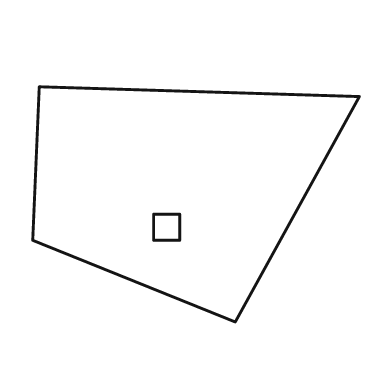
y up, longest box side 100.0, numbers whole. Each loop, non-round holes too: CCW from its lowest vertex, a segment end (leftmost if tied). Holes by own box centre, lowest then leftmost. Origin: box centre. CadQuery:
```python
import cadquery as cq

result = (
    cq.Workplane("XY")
    .moveTo(12.0, -36.0)
    .lineTo(50.0, 33.0)
    .lineTo(-48.0, 36.0)
    .lineTo(-50.0, -11.0)
    .close()
    .moveTo(-13.0, -11.0)
    .lineTo(-5.0, -11.0)
    .lineTo(-5.0, -3.0)
    .lineTo(-13.0, -3.0)
    .close()
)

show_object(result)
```